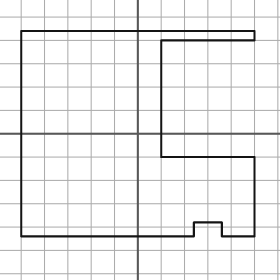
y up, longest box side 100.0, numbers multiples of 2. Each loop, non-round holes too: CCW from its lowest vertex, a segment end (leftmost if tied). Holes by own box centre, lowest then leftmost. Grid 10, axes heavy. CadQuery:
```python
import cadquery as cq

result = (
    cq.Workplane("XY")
    .moveTo(-50.0, -44.0)
    .lineTo(24.0, -44.0)
    .lineTo(24.0, -38.0)
    .lineTo(36.0, -38.0)
    .lineTo(36.0, -44.0)
    .lineTo(50.0, -44.0)
    .lineTo(50.0, -10.0)
    .lineTo(10.0, -10.0)
    .lineTo(10.0, 40.0)
    .lineTo(50.0, 40.0)
    .lineTo(50.0, 44.0)
    .lineTo(-50.0, 44.0)
    .close()
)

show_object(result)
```